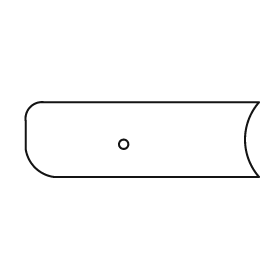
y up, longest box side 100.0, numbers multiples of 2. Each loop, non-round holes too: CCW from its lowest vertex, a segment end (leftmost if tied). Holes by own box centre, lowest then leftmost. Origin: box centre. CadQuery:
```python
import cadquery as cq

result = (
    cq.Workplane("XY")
    .moveTo(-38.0, -16.0)
    .lineTo(50.0, -16.0)
    .threePointArc((44.0, 0.0), (50.0, 16.0))
    .lineTo(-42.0, 16.0)
    .threePointArc((-48.0, 14.0), (-50.0, 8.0))
    .lineTo(-50.0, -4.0)
    .threePointArc((-46.0, -12.0), (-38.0, -16.0))
    .close()
    .moveTo(-8.0, -2.0)
    .circle(2.0)
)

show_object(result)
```